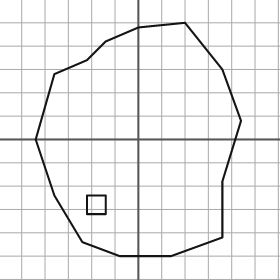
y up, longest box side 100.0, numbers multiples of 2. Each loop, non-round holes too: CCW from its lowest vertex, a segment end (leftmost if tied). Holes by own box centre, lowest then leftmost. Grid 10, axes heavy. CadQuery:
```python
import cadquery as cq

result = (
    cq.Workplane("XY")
    .moveTo(-8.0, -50.0)
    .lineTo(14.0, -50.0)
    .lineTo(36.0, -42.0)
    .lineTo(36.0, -18.0)
    .lineTo(44.0, 8.0)
    .lineTo(36.0, 30.0)
    .lineTo(20.0, 50.0)
    .lineTo(0.0, 48.0)
    .lineTo(-14.0, 42.0)
    .lineTo(-22.0, 34.0)
    .lineTo(-36.0, 28.0)
    .lineTo(-44.0, 0.0)
    .lineTo(-36.0, -24.0)
    .lineTo(-24.0, -44.0)
    .close()
    .moveTo(-22.0, -32.0)
    .lineTo(-14.0, -32.0)
    .lineTo(-14.0, -24.0)
    .lineTo(-22.0, -24.0)
    .close()
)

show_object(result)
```